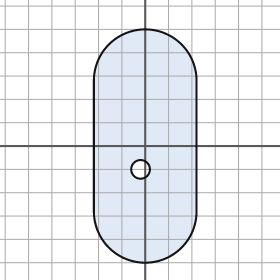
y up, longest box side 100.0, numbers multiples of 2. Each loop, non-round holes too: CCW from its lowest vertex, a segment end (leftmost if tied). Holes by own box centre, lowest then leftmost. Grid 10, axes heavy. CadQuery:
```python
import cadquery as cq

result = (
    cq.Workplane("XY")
    .moveTo(-22.0, -28.0)
    .threePointArc((0.0, -50.0), (22.0, -28.0))
    .lineTo(22.0, 28.0)
    .threePointArc((0.0, 50.0), (-22.0, 28.0))
    .close()
    .moveTo(-2.0, -10.0)
    .circle(4.0)
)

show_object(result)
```